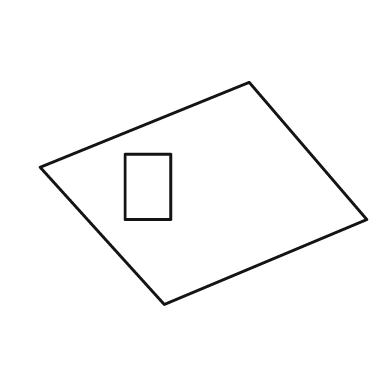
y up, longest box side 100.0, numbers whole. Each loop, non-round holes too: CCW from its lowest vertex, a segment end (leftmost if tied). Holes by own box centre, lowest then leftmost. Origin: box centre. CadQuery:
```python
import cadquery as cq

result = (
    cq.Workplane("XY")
    .moveTo(-12.0, -34.0)
    .lineTo(50.0, -8.0)
    .lineTo(14.0, 34.0)
    .lineTo(-50.0, 8.0)
    .close()
    .moveTo(-24.0, -8.0)
    .lineTo(-10.0, -8.0)
    .lineTo(-10.0, 12.0)
    .lineTo(-24.0, 12.0)
    .close()
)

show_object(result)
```